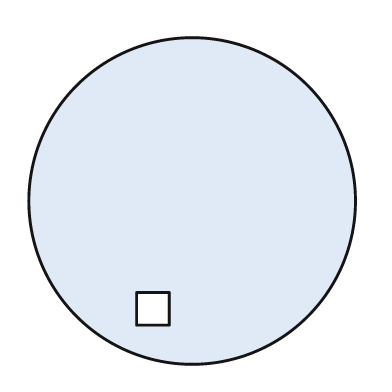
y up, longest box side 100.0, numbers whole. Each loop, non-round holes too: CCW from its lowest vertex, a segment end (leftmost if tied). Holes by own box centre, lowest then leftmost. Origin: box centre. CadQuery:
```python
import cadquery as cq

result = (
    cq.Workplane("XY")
    .moveTo(0.0, 0.0)
    .circle(50.0)
    .moveTo(-17.0, -38.0)
    .lineTo(-7.0, -38.0)
    .lineTo(-7.0, -28.0)
    .lineTo(-17.0, -28.0)
    .close()
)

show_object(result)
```